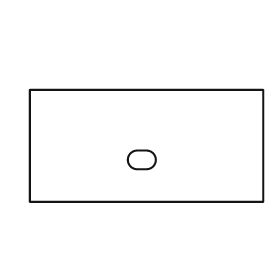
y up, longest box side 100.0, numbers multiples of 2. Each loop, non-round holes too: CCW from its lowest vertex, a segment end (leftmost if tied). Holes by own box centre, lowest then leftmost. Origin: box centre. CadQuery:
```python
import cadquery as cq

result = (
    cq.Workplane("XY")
    .moveTo(-50.0, -24.0)
    .lineTo(50.0, -24.0)
    .lineTo(50.0, 24.0)
    .lineTo(-50.0, 24.0)
    .close()
    .moveTo(-4.0, -10.0)
    .lineTo(0.0, -10.0)
    .threePointArc((4.0, -6.0), (0.0, -2.0))
    .lineTo(-4.0, -2.0)
    .threePointArc((-8.0, -6.0), (-4.0, -10.0))
    .close()
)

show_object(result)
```